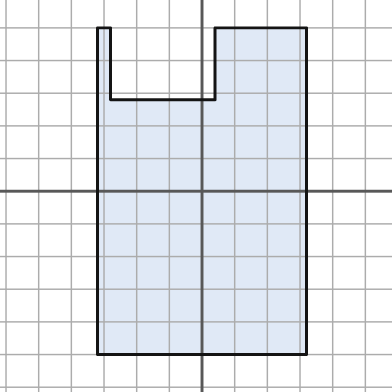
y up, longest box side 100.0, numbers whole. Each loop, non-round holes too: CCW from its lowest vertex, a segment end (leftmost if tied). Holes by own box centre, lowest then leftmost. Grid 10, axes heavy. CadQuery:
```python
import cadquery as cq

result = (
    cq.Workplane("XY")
    .moveTo(-32.0, -50.0)
    .lineTo(32.0, -50.0)
    .lineTo(32.0, 50.0)
    .lineTo(4.0, 50.0)
    .lineTo(4.0, 28.0)
    .lineTo(-28.0, 28.0)
    .lineTo(-28.0, 50.0)
    .lineTo(-32.0, 50.0)
    .close()
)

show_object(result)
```